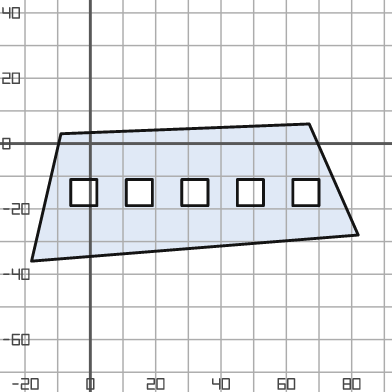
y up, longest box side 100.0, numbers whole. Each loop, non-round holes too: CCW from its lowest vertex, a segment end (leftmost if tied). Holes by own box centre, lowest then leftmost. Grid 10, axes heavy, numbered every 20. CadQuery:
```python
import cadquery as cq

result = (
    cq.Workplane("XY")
    .moveTo(-18.0, -36.0)
    .lineTo(82.0, -28.0)
    .lineTo(67.0, 6.0)
    .lineTo(-9.0, 3.0)
    .close()
    .moveTo(-6.0, -19.0)
    .lineTo(2.0, -19.0)
    .lineTo(2.0, -11.0)
    .lineTo(-6.0, -11.0)
    .close()
    .moveTo(11.0, -19.0)
    .lineTo(19.0, -19.0)
    .lineTo(19.0, -11.0)
    .lineTo(11.0, -11.0)
    .close()
    .moveTo(28.0, -19.0)
    .lineTo(36.0, -19.0)
    .lineTo(36.0, -11.0)
    .lineTo(28.0, -11.0)
    .close()
    .moveTo(45.0, -19.0)
    .lineTo(53.0, -19.0)
    .lineTo(53.0, -11.0)
    .lineTo(45.0, -11.0)
    .close()
    .moveTo(62.0, -19.0)
    .lineTo(70.0, -19.0)
    .lineTo(70.0, -11.0)
    .lineTo(62.0, -11.0)
    .close()
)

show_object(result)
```